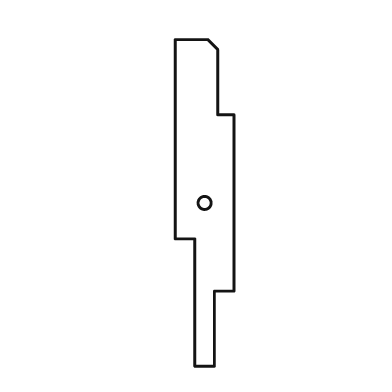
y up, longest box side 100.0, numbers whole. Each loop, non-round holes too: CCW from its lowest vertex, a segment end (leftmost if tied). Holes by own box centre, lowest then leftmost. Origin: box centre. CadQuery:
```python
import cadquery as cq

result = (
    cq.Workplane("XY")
    .moveTo(-3.0, -50.0)
    .lineTo(3.0, -50.0)
    .lineTo(3.0, -27.0)
    .lineTo(9.0, -27.0)
    .lineTo(9.0, 27.0)
    .lineTo(4.0, 27.0)
    .lineTo(4.0, 47.0)
    .lineTo(1.0, 50.0)
    .lineTo(-9.0, 50.0)
    .lineTo(-9.0, -11.0)
    .lineTo(-3.0, -11.0)
    .close()
    .moveTo(0.0, 0.0)
    .circle(2.0)
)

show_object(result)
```